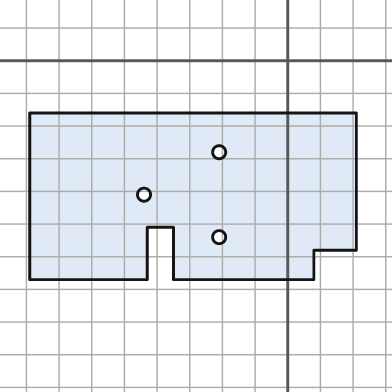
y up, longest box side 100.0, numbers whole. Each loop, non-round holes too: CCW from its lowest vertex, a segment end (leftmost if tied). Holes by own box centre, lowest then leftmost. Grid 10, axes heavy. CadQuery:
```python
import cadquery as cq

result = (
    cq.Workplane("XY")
    .moveTo(-79.0, -67.0)
    .lineTo(-43.0, -67.0)
    .lineTo(-43.0, -51.0)
    .lineTo(-35.0, -51.0)
    .lineTo(-35.0, -67.0)
    .lineTo(8.0, -67.0)
    .lineTo(8.0, -58.0)
    .lineTo(21.0, -58.0)
    .lineTo(21.0, -16.0)
    .lineTo(-79.0, -16.0)
    .close()
    .moveTo(-21.0, -54.0)
    .circle(2.0)
    .moveTo(-44.0, -41.0)
    .circle(2.0)
    .moveTo(-21.0, -28.0)
    .circle(2.0)
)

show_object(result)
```